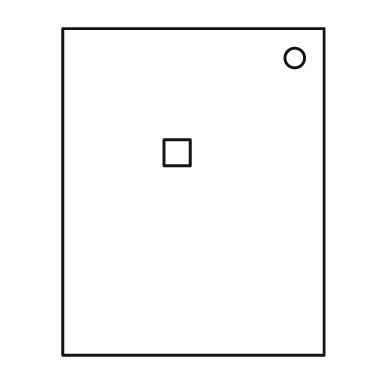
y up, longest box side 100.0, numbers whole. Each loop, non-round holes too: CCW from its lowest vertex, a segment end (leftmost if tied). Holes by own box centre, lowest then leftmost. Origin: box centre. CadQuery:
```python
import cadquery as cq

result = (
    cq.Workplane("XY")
    .moveTo(-40.0, -50.0)
    .lineTo(40.0, -50.0)
    .lineTo(40.0, 50.0)
    .lineTo(-40.0, 50.0)
    .close()
    .moveTo(-9.0, 8.0)
    .lineTo(-1.0, 8.0)
    .lineTo(-1.0, 16.0)
    .lineTo(-9.0, 16.0)
    .close()
    .moveTo(31.0, 41.0)
    .circle(3.0)
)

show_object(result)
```